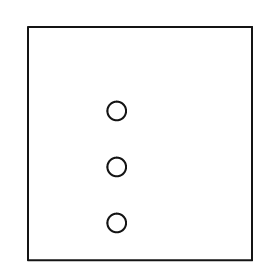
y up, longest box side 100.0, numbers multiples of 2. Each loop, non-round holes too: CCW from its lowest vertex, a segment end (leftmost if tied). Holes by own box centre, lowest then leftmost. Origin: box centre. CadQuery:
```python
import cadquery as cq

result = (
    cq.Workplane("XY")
    .moveTo(-48.0, -50.0)
    .lineTo(48.0, -50.0)
    .lineTo(48.0, 50.0)
    .lineTo(-48.0, 50.0)
    .close()
    .moveTo(-10.0, -34.0)
    .circle(4.0)
    .moveTo(-10.0, -10.0)
    .circle(4.0)
    .moveTo(-10.0, 14.0)
    .circle(4.0)
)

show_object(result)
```